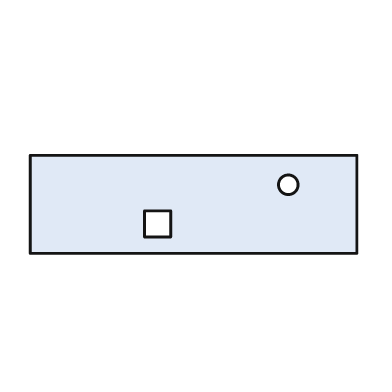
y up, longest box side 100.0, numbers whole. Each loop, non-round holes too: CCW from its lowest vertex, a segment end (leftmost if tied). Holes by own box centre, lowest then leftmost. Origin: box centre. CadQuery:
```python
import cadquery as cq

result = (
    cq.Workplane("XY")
    .moveTo(-50.0, -15.0)
    .lineTo(50.0, -15.0)
    .lineTo(50.0, 15.0)
    .lineTo(-50.0, 15.0)
    .close()
    .moveTo(-15.0, -10.0)
    .lineTo(-7.0, -10.0)
    .lineTo(-7.0, -2.0)
    .lineTo(-15.0, -2.0)
    .close()
    .moveTo(29.0, 6.0)
    .circle(3.0)
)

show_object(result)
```